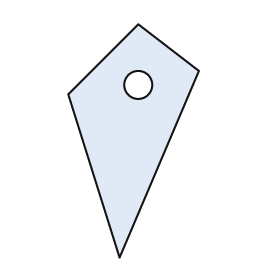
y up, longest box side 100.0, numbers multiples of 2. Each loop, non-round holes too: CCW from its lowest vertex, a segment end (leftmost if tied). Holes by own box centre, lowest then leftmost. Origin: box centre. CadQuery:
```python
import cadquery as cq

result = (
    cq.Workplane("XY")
    .moveTo(-6.0, -50.0)
    .lineTo(28.0, 30.0)
    .lineTo(2.0, 50.0)
    .lineTo(-28.0, 20.0)
    .close()
    .moveTo(2.0, 24.0)
    .circle(6.0)
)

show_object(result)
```